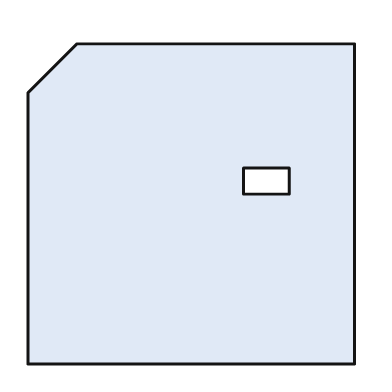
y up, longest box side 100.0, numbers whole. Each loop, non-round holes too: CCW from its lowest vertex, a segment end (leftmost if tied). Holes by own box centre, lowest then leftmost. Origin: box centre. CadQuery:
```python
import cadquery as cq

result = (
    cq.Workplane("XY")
    .moveTo(-50.0, -49.0)
    .lineTo(50.0, -49.0)
    .lineTo(50.0, 49.0)
    .lineTo(-35.0, 49.0)
    .lineTo(-50.0, 34.0)
    .close()
    .moveTo(16.0, 3.0)
    .lineTo(30.0, 3.0)
    .lineTo(30.0, 11.0)
    .lineTo(16.0, 11.0)
    .close()
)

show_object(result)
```